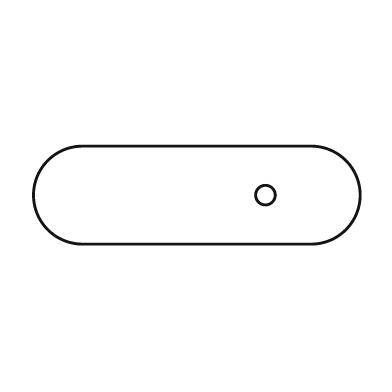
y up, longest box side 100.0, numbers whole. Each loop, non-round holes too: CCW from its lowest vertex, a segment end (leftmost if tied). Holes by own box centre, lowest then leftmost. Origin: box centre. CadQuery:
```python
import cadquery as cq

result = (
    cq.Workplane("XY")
    .moveTo(-35.0, -15.0)
    .lineTo(35.0, -15.0)
    .threePointArc((50.0, 0.0), (35.0, 15.0))
    .lineTo(-35.0, 15.0)
    .threePointArc((-50.0, 0.0), (-35.0, -15.0))
    .close()
    .moveTo(21.0, 0.0)
    .circle(3.0)
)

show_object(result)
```